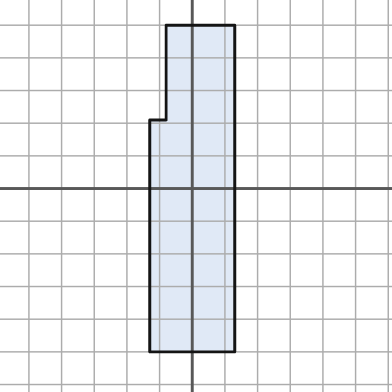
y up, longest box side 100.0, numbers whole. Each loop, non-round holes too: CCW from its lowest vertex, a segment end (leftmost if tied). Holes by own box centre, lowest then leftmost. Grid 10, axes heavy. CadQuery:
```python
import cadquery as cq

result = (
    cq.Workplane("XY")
    .moveTo(-13.0, -50.0)
    .lineTo(13.0, -50.0)
    .lineTo(13.0, 50.0)
    .lineTo(-8.0, 50.0)
    .lineTo(-8.0, 21.0)
    .lineTo(-13.0, 21.0)
    .close()
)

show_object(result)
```